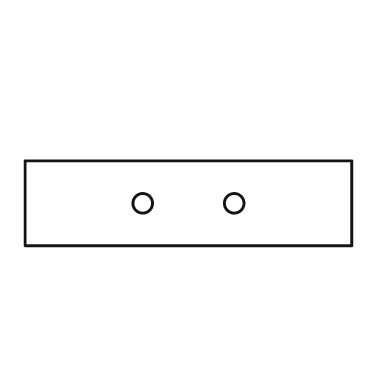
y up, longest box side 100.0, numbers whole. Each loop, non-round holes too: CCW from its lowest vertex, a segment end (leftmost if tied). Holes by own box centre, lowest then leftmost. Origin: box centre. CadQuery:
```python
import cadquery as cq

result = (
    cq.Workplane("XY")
    .moveTo(-50.0, -13.0)
    .lineTo(50.0, -13.0)
    .lineTo(50.0, 13.0)
    .lineTo(-50.0, 13.0)
    .close()
    .moveTo(-14.0, 0.0)
    .circle(3.0)
    .moveTo(14.0, 0.0)
    .circle(3.0)
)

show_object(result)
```